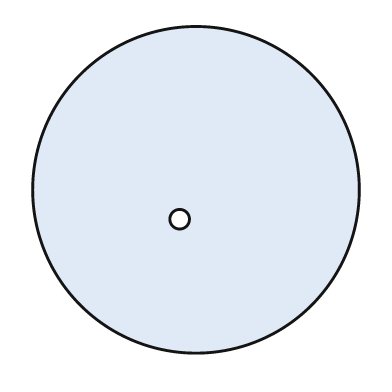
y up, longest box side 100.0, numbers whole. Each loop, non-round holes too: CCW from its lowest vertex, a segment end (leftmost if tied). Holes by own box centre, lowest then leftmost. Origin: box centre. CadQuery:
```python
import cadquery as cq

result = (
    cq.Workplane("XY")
    .moveTo(0.0, 0.0)
    .circle(50.0)
    .moveTo(-5.0, -9.0)
    .circle(3.0)
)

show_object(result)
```